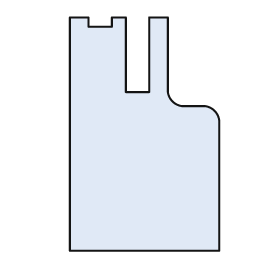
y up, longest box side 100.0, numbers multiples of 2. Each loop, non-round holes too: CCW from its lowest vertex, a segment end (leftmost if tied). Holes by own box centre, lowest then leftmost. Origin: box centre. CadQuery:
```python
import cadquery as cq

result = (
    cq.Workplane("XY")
    .moveTo(-32.0, -50.0)
    .lineTo(32.0, -50.0)
    .lineTo(32.0, 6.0)
    .threePointArc((30.0, 10.0), (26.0, 12.0))
    .lineTo(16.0, 12.0)
    .threePointArc((12.0, 14.0), (10.0, 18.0))
    .lineTo(10.0, 50.0)
    .lineTo(2.0, 50.0)
    .lineTo(2.0, 18.0)
    .lineTo(-8.0, 18.0)
    .lineTo(-8.0, 50.0)
    .lineTo(-14.0, 50.0)
    .lineTo(-14.0, 46.0)
    .lineTo(-24.0, 46.0)
    .lineTo(-24.0, 50.0)
    .lineTo(-32.0, 50.0)
    .close()
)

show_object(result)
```